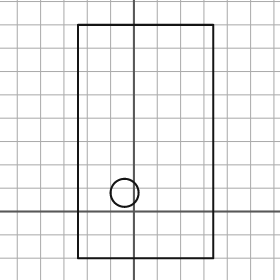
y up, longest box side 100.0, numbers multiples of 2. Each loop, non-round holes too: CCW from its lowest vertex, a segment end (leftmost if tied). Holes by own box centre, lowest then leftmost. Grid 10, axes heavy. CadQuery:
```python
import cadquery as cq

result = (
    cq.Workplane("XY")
    .moveTo(-24.0, -20.0)
    .lineTo(34.0, -20.0)
    .lineTo(34.0, 80.0)
    .lineTo(-24.0, 80.0)
    .close()
    .moveTo(-4.0, 8.0)
    .circle(6.0)
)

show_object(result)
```